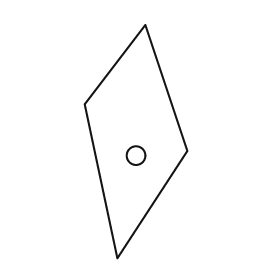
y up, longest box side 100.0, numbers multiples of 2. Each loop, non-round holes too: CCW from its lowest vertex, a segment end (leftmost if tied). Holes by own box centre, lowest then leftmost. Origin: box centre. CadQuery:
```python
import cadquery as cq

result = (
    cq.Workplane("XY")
    .moveTo(-8.0, -50.0)
    .lineTo(22.0, -4.0)
    .lineTo(4.0, 50.0)
    .lineTo(-22.0, 16.0)
    .close()
    .moveTo(0.0, -6.0)
    .circle(4.0)
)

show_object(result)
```